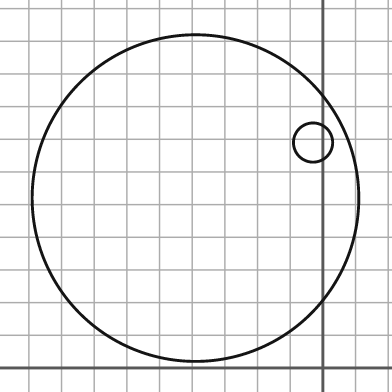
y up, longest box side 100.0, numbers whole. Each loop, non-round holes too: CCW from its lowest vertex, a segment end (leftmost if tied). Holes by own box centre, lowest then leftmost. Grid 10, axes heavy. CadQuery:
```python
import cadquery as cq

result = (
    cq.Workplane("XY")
    .moveTo(-39.0, 52.0)
    .circle(50.0)
    .moveTo(-3.0, 69.0)
    .circle(6.0)
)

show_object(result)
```